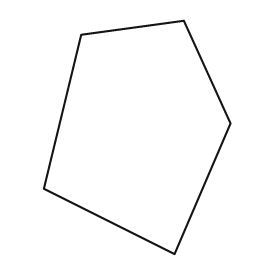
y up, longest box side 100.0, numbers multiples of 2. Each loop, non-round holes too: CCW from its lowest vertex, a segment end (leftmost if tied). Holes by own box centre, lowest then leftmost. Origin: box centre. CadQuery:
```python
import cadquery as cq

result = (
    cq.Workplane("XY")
    .moveTo(16.0, -50.0)
    .lineTo(40.0, 6.0)
    .lineTo(20.0, 50.0)
    .lineTo(-24.0, 44.0)
    .lineTo(-40.0, -22.0)
    .close()
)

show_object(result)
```